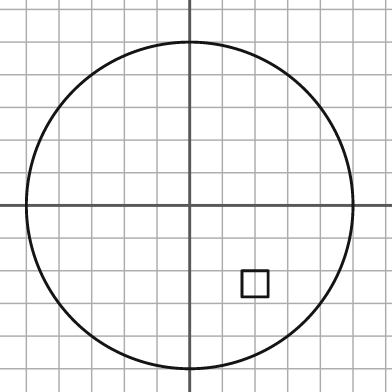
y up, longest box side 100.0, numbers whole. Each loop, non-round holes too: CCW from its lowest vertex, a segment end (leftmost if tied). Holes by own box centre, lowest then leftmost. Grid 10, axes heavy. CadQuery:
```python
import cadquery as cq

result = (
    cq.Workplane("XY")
    .moveTo(0.0, 0.0)
    .circle(50.0)
    .moveTo(16.0, -28.0)
    .lineTo(24.0, -28.0)
    .lineTo(24.0, -20.0)
    .lineTo(16.0, -20.0)
    .close()
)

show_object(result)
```